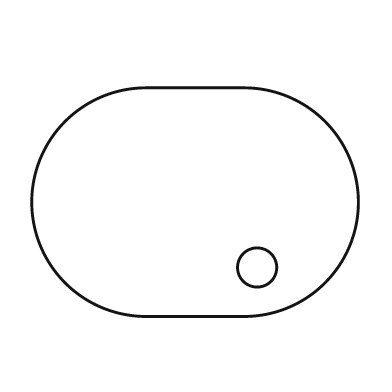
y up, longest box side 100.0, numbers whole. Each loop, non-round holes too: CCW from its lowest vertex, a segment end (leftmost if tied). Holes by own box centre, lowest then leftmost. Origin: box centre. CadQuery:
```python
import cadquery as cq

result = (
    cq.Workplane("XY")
    .moveTo(-15.0, -35.0)
    .lineTo(15.0, -35.0)
    .threePointArc((50.0, 0.0), (15.0, 35.0))
    .lineTo(-15.0, 35.0)
    .threePointArc((-50.0, 0.0), (-15.0, -35.0))
    .close()
    .moveTo(19.0, -20.0)
    .circle(6.0)
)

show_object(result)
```